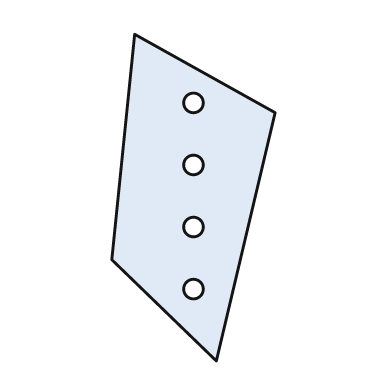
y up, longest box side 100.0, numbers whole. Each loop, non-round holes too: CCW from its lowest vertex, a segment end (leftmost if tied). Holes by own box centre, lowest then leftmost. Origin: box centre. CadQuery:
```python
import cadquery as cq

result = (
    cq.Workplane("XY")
    .moveTo(7.0, -50.0)
    .lineTo(25.0, 26.0)
    .lineTo(-18.0, 50.0)
    .lineTo(-25.0, -19.0)
    .close()
    .moveTo(0.0, -28.0)
    .circle(3.0)
    .moveTo(0.0, -9.0)
    .circle(3.0)
    .moveTo(0.0, 10.0)
    .circle(3.0)
    .moveTo(0.0, 29.0)
    .circle(3.0)
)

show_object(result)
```